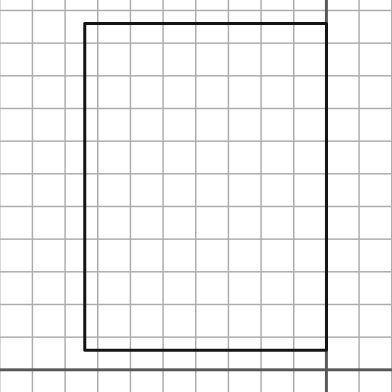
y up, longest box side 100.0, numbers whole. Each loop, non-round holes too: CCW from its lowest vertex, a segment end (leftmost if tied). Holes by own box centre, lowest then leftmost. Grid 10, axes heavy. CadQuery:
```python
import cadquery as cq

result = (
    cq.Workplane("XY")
    .moveTo(-74.0, 6.0)
    .lineTo(0.0, 6.0)
    .lineTo(0.0, 106.0)
    .lineTo(-74.0, 106.0)
    .close()
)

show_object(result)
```